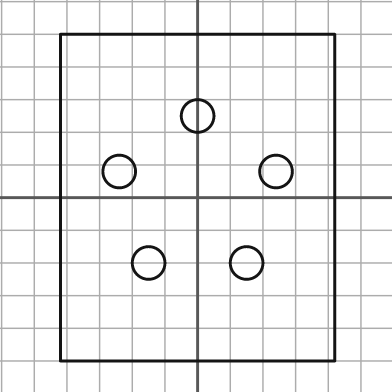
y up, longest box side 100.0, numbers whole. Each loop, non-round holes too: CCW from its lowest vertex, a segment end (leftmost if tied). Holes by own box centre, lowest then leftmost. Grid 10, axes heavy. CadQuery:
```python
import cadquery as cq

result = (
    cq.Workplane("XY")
    .moveTo(-42.0, -50.0)
    .lineTo(42.0, -50.0)
    .lineTo(42.0, 50.0)
    .lineTo(-42.0, 50.0)
    .close()
    .moveTo(-15.0, -20.0)
    .circle(5.0)
    .moveTo(15.0, -20.0)
    .circle(5.0)
    .moveTo(-24.0, 8.0)
    .circle(5.0)
    .moveTo(24.0, 8.0)
    .circle(5.0)
    .moveTo(0.0, 25.0)
    .circle(5.0)
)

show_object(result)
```